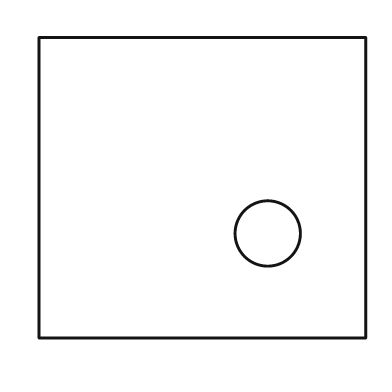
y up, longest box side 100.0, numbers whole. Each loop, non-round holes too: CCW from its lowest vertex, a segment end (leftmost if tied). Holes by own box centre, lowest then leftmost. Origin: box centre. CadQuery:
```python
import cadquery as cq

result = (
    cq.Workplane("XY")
    .moveTo(-50.0, -46.0)
    .lineTo(50.0, -46.0)
    .lineTo(50.0, 46.0)
    .lineTo(-50.0, 46.0)
    .close()
    .moveTo(20.0, -14.0)
    .circle(10.0)
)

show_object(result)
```